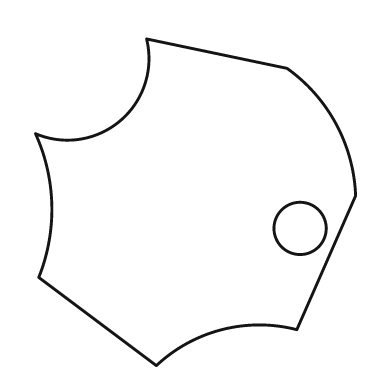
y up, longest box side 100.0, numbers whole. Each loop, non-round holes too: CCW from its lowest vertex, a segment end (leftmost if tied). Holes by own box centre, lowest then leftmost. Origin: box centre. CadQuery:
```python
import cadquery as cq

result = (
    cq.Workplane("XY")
    .moveTo(-12.0, -50.0)
    .threePointArc((8.0, -39.0), (31.0, -39.0))
    .lineTo(49.0, 2.0)
    .threePointArc((43.0, 24.0), (28.0, 41.0))
    .lineTo(-15.0, 50.0)
    .threePointArc((-23.0, 25.0), (-49.0, 21.0))
    .threePointArc((-44.0, -1.0), (-48.0, -23.0))
    .close()
    .moveTo(32.0, -8.0)
    .circle(8.0)
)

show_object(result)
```